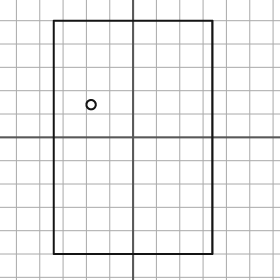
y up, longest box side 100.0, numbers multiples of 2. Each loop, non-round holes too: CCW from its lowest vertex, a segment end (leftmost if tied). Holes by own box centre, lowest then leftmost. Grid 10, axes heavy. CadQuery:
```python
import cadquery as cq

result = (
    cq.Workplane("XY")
    .moveTo(-34.0, -50.0)
    .lineTo(34.0, -50.0)
    .lineTo(34.0, 50.0)
    .lineTo(-34.0, 50.0)
    .close()
    .moveTo(-18.0, 14.0)
    .circle(2.0)
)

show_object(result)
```